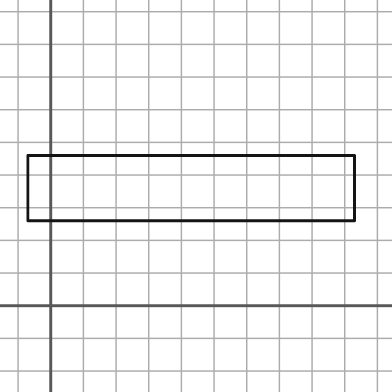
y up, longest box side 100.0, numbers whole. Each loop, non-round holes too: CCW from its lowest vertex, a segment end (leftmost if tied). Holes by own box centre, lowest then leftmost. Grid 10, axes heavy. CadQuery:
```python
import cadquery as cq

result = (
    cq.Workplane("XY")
    .moveTo(-7.0, 26.0)
    .lineTo(93.0, 26.0)
    .lineTo(93.0, 46.0)
    .lineTo(-7.0, 46.0)
    .close()
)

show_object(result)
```